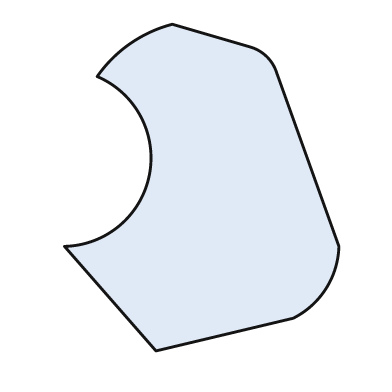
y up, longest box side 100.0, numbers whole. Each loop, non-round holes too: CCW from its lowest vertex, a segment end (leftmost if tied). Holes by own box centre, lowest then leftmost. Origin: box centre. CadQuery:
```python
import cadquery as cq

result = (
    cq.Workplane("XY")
    .moveTo(-14.0, -50.0)
    .lineTo(28.0, -40.0)
    .threePointArc((38.0, -31.0), (42.0, -18.0))
    .lineTo(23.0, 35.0)
    .threePointArc((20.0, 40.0), (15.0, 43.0))
    .lineTo(-9.0, 50.0)
    .threePointArc((-22.0, 44.0), (-32.0, 34.0))
    .threePointArc((-16.0, 4.0), (-42.0, -18.0))
    .close()
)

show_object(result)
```